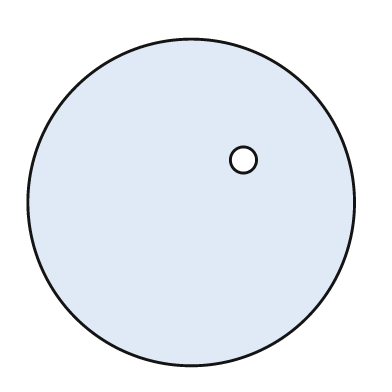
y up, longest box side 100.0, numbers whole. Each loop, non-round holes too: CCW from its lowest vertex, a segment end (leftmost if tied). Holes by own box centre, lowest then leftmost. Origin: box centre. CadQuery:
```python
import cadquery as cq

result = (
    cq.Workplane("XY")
    .moveTo(0.0, 0.0)
    .circle(50.0)
    .moveTo(16.0, 13.0)
    .circle(4.0)
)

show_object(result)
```